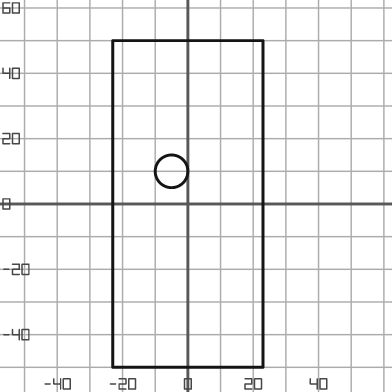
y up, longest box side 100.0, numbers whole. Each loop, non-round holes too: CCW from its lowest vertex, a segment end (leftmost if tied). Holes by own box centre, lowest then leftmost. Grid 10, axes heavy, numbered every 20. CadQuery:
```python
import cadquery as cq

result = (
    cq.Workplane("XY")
    .moveTo(-23.0, -50.0)
    .lineTo(23.0, -50.0)
    .lineTo(23.0, 50.0)
    .lineTo(-23.0, 50.0)
    .close()
    .moveTo(-5.0, 10.0)
    .circle(5.0)
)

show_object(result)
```